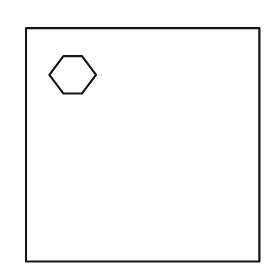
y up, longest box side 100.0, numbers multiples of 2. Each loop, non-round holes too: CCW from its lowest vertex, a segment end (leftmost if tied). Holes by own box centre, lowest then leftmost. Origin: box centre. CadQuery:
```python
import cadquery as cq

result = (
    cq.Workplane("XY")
    .moveTo(-50.0, -50.0)
    .lineTo(50.0, -50.0)
    .lineTo(50.0, 50.0)
    .lineTo(-50.0, 50.0)
    .close()
    .moveTo(-34.0, 22.0)
    .lineTo(-26.0, 22.0)
    .lineTo(-20.0, 30.0)
    .lineTo(-26.0, 38.0)
    .lineTo(-34.0, 38.0)
    .lineTo(-40.0, 30.0)
    .close()
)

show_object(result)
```